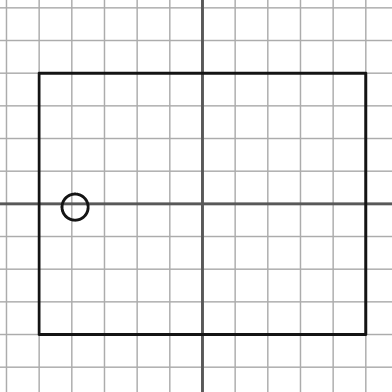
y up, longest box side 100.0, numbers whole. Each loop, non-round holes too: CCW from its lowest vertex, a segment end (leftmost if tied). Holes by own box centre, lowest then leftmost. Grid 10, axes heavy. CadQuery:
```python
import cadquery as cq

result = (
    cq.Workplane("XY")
    .moveTo(-50.0, -40.0)
    .lineTo(50.0, -40.0)
    .lineTo(50.0, 40.0)
    .lineTo(-50.0, 40.0)
    .close()
    .moveTo(-39.0, -1.0)
    .circle(4.0)
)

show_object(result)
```